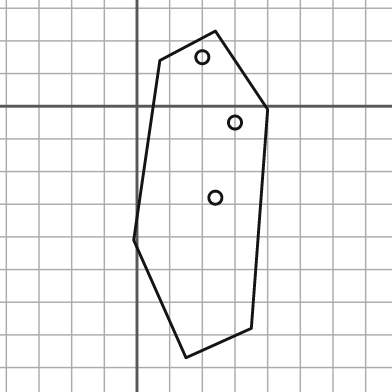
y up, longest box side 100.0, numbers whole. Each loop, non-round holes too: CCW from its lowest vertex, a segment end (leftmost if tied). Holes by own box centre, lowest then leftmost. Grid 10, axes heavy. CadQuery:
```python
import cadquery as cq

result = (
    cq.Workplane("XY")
    .moveTo(15.0, -77.0)
    .lineTo(35.0, -68.0)
    .lineTo(40.0, -1.0)
    .lineTo(24.0, 23.0)
    .lineTo(7.0, 14.0)
    .lineTo(-1.0, -41.0)
    .close()
    .moveTo(24.0, -28.0)
    .circle(2.0)
    .moveTo(30.0, -5.0)
    .circle(2.0)
    .moveTo(20.0, 15.0)
    .circle(2.0)
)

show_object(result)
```